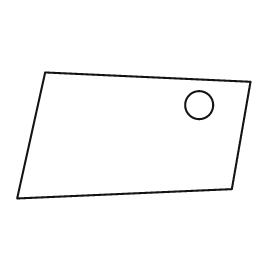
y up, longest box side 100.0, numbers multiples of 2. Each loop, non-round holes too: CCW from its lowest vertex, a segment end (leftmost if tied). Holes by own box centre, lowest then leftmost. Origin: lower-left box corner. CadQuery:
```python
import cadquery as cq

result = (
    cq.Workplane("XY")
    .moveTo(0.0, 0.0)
    .lineTo(92.0, 4.0)
    .lineTo(100.0, 50.0)
    .lineTo(12.0, 54.0)
    .close()
    .moveTo(78.0, 40.0)
    .circle(6.0)
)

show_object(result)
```